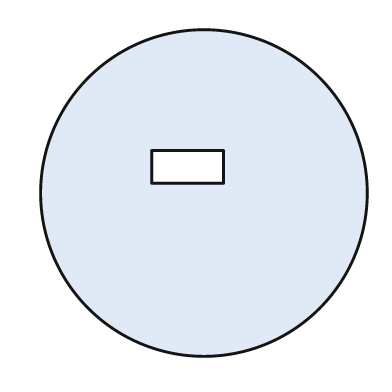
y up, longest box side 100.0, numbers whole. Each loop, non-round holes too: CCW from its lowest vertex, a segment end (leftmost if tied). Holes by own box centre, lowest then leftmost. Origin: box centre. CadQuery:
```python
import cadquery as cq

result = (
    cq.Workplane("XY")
    .moveTo(0.0, 0.0)
    .circle(50.0)
    .moveTo(-16.0, 3.0)
    .lineTo(6.0, 3.0)
    .lineTo(6.0, 13.0)
    .lineTo(-16.0, 13.0)
    .close()
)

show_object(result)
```